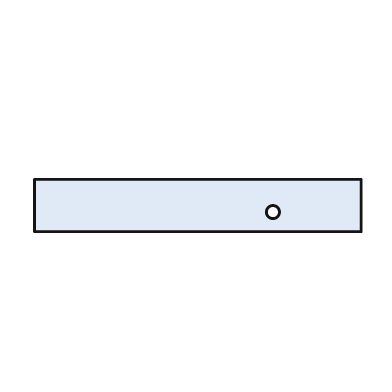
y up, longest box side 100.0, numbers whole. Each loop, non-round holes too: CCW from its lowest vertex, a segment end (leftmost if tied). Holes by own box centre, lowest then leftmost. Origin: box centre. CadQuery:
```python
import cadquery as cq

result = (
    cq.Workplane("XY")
    .moveTo(-50.0, -8.0)
    .lineTo(50.0, -8.0)
    .lineTo(50.0, 8.0)
    .lineTo(-50.0, 8.0)
    .close()
    .moveTo(23.0, -2.0)
    .circle(2.0)
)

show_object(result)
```